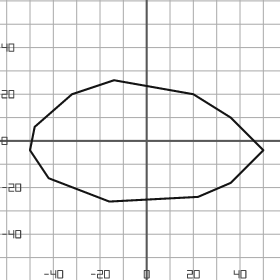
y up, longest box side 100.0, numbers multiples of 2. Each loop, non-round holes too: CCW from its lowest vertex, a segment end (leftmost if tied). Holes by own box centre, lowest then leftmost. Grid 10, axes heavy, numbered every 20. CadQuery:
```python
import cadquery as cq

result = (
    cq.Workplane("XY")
    .moveTo(-16.0, -26.0)
    .lineTo(22.0, -24.0)
    .lineTo(36.0, -18.0)
    .lineTo(50.0, -4.0)
    .lineTo(36.0, 10.0)
    .lineTo(20.0, 20.0)
    .lineTo(-14.0, 26.0)
    .lineTo(-32.0, 20.0)
    .lineTo(-48.0, 6.0)
    .lineTo(-50.0, -4.0)
    .lineTo(-42.0, -16.0)
    .close()
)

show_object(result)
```